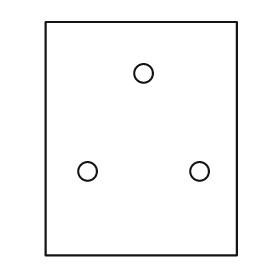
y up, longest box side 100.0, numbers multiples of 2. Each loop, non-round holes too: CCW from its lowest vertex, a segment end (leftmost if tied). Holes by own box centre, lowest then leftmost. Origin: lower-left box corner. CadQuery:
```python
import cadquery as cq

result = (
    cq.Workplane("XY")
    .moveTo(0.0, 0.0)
    .lineTo(82.0, 0.0)
    .lineTo(82.0, 100.0)
    .lineTo(0.0, 100.0)
    .close()
    .moveTo(18.0, 36.0)
    .circle(4.0)
    .moveTo(66.0, 36.0)
    .circle(4.0)
    .moveTo(42.0, 78.0)
    .circle(4.0)
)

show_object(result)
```